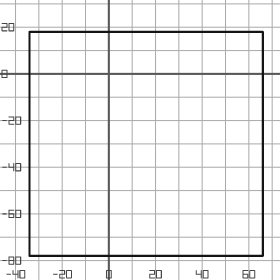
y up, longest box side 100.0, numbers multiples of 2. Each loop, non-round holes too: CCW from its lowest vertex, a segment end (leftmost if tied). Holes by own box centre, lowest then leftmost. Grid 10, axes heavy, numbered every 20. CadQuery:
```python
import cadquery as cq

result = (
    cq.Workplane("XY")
    .moveTo(-34.0, -78.0)
    .lineTo(66.0, -78.0)
    .lineTo(66.0, 18.0)
    .lineTo(-34.0, 18.0)
    .close()
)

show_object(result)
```